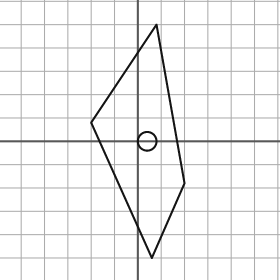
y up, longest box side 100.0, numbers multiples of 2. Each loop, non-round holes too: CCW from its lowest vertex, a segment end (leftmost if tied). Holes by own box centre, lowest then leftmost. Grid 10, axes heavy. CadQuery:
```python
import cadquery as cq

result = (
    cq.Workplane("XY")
    .moveTo(6.0, -50.0)
    .lineTo(20.0, -18.0)
    .lineTo(8.0, 50.0)
    .lineTo(-20.0, 8.0)
    .close()
    .moveTo(4.0, 0.0)
    .circle(4.0)
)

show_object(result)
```